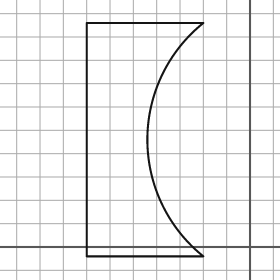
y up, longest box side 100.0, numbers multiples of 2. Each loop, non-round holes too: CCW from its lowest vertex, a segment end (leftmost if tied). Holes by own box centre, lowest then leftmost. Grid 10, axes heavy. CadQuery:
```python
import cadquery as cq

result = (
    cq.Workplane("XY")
    .moveTo(-70.0, -4.0)
    .lineTo(-20.0, -4.0)
    .threePointArc((-44.0, 46.0), (-20.0, 96.0))
    .lineTo(-70.0, 96.0)
    .close()
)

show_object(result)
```